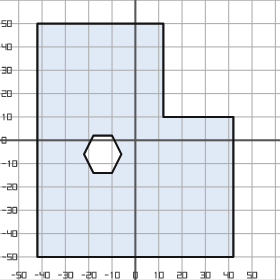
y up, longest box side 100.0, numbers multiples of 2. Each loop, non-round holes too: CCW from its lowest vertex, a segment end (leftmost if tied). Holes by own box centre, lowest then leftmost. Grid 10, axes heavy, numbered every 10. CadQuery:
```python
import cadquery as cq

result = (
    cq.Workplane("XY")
    .moveTo(-42.0, -50.0)
    .lineTo(42.0, -50.0)
    .lineTo(42.0, 10.0)
    .lineTo(12.0, 10.0)
    .lineTo(12.0, 50.0)
    .lineTo(-42.0, 50.0)
    .close()
    .moveTo(-18.0, -14.0)
    .lineTo(-10.0, -14.0)
    .lineTo(-6.0, -6.0)
    .lineTo(-10.0, 2.0)
    .lineTo(-18.0, 2.0)
    .lineTo(-22.0, -6.0)
    .close()
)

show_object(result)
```